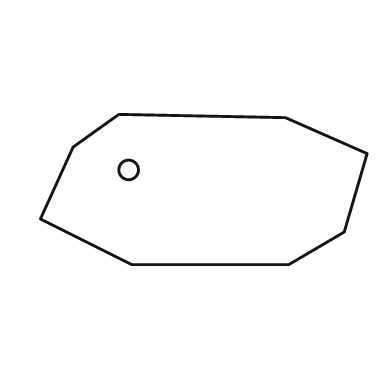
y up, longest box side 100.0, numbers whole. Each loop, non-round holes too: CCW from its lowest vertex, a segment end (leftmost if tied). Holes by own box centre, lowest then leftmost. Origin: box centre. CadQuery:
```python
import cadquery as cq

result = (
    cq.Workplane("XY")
    .moveTo(-22.0, -23.0)
    .lineTo(26.0, -23.0)
    .lineTo(43.0, -13.0)
    .lineTo(50.0, 11.0)
    .lineTo(25.0, 22.0)
    .lineTo(-26.0, 23.0)
    .lineTo(-40.0, 13.0)
    .lineTo(-50.0, -9.0)
    .close()
    .moveTo(-23.0, 6.0)
    .circle(3.0)
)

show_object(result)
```